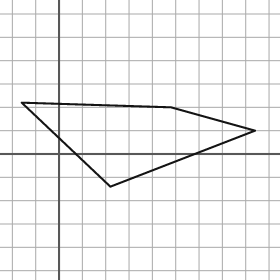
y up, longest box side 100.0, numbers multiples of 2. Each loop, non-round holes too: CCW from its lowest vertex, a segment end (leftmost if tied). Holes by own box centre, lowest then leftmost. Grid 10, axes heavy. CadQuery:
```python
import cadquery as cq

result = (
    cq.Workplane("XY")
    .moveTo(22.0, -14.0)
    .lineTo(84.0, 10.0)
    .lineTo(48.0, 20.0)
    .lineTo(-16.0, 22.0)
    .close()
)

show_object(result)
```